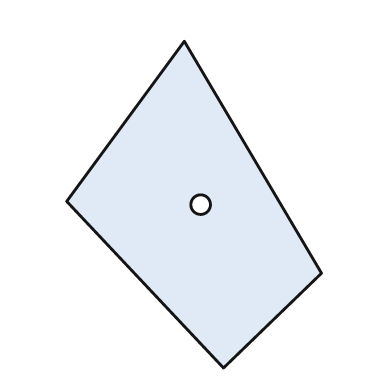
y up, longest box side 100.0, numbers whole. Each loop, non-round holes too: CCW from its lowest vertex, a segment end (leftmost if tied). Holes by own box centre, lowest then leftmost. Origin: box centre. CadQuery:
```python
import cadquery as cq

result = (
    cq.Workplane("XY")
    .moveTo(9.0, -50.0)
    .lineTo(39.0, -21.0)
    .lineTo(-3.0, 50.0)
    .lineTo(-39.0, 1.0)
    .close()
    .moveTo(2.0, 0.0)
    .circle(3.0)
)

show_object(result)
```